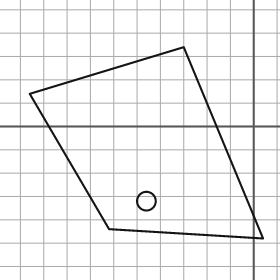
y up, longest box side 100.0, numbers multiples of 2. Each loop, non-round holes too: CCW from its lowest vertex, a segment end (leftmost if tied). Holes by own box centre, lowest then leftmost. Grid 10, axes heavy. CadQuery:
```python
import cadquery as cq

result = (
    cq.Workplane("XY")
    .moveTo(4.0, -48.0)
    .lineTo(-30.0, 34.0)
    .lineTo(-96.0, 14.0)
    .lineTo(-62.0, -44.0)
    .close()
    .moveTo(-46.0, -32.0)
    .circle(4.0)
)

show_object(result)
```